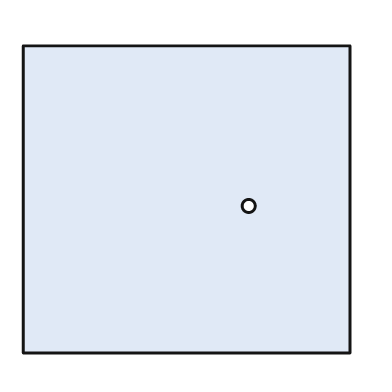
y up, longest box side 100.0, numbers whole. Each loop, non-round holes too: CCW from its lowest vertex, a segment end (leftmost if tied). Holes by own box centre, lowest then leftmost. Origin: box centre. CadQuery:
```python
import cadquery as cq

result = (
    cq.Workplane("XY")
    .moveTo(-50.0, -47.0)
    .lineTo(50.0, -47.0)
    .lineTo(50.0, 47.0)
    .lineTo(-50.0, 47.0)
    .close()
    .moveTo(19.0, -2.0)
    .circle(2.0)
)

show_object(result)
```